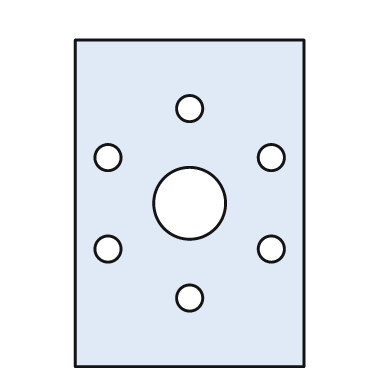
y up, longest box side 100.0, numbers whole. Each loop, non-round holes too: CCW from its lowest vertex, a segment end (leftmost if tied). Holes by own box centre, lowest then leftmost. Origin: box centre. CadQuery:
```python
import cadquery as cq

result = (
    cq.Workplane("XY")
    .moveTo(-35.0, -50.0)
    .lineTo(35.0, -50.0)
    .lineTo(35.0, 50.0)
    .lineTo(-35.0, 50.0)
    .close()
    .moveTo(0.0, -29.0)
    .circle(4.0)
    .moveTo(-25.0, -14.0)
    .circle(4.0)
    .moveTo(25.0, -14.0)
    .circle(4.0)
    .moveTo(0.0, 0.0)
    .circle(11.0)
    .moveTo(-25.0, 14.0)
    .circle(4.0)
    .moveTo(25.0, 14.0)
    .circle(4.0)
    .moveTo(0.0, 29.0)
    .circle(4.0)
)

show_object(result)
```